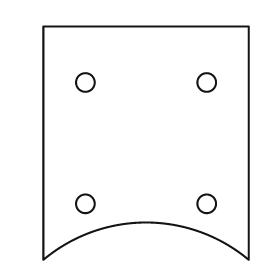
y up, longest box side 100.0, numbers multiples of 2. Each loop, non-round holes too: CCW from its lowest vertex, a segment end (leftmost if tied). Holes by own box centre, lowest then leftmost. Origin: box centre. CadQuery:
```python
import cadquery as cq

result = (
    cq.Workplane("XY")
    .moveTo(-44.0, -50.0)
    .threePointArc((0.0, -34.0), (44.0, -50.0))
    .lineTo(44.0, 50.0)
    .lineTo(-44.0, 50.0)
    .close()
    .moveTo(-26.0, -26.0)
    .circle(4.0)
    .moveTo(26.0, -26.0)
    .circle(4.0)
    .moveTo(-26.0, 26.0)
    .circle(4.0)
    .moveTo(26.0, 26.0)
    .circle(4.0)
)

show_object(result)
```